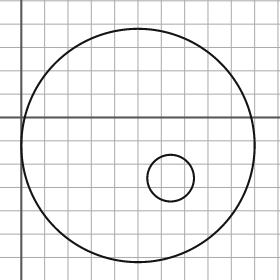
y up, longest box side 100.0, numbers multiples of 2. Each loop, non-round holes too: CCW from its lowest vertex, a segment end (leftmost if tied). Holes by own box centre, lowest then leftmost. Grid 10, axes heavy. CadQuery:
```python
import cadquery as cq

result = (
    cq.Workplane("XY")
    .moveTo(50.0, -12.0)
    .circle(50.0)
    .moveTo(64.0, -26.0)
    .circle(10.0)
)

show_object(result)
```